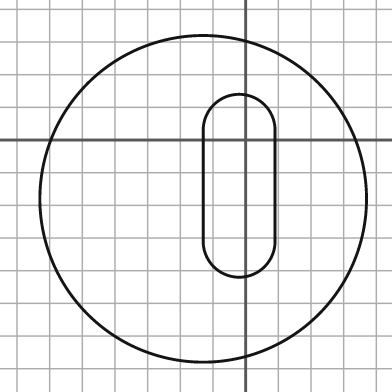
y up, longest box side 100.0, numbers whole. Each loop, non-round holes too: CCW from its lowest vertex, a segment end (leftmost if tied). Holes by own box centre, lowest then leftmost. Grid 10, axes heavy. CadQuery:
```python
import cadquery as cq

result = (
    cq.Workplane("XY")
    .moveTo(-13.0, -18.0)
    .circle(50.0)
    .moveTo(-13.0, -31.0)
    .threePointArc((-2.0, -42.0), (9.0, -31.0))
    .lineTo(9.0, 3.0)
    .threePointArc((-2.0, 14.0), (-13.0, 3.0))
    .close()
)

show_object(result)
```